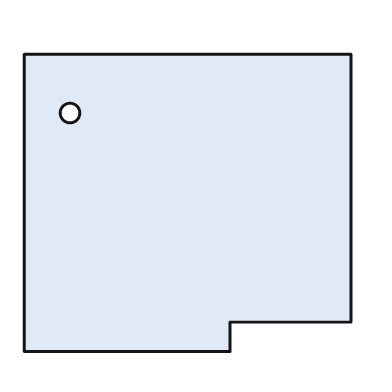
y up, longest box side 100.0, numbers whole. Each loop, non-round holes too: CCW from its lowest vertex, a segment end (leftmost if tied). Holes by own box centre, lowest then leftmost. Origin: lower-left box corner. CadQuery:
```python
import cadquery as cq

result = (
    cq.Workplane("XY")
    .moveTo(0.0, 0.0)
    .lineTo(63.0, 0.0)
    .lineTo(63.0, 9.0)
    .lineTo(100.0, 9.0)
    .lineTo(100.0, 91.0)
    .lineTo(0.0, 91.0)
    .close()
    .moveTo(14.0, 73.0)
    .circle(3.0)
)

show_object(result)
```